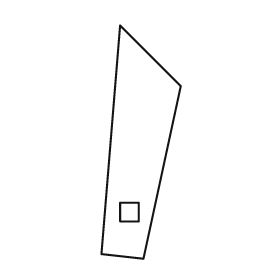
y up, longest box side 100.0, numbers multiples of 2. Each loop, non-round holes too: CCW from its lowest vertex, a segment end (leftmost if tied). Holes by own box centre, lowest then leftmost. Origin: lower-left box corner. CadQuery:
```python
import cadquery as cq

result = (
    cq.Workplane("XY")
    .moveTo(18.0, 0.0)
    .lineTo(34.0, 74.0)
    .lineTo(8.0, 100.0)
    .lineTo(0.0, 2.0)
    .close()
    .moveTo(8.0, 16.0)
    .lineTo(16.0, 16.0)
    .lineTo(16.0, 24.0)
    .lineTo(8.0, 24.0)
    .close()
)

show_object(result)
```